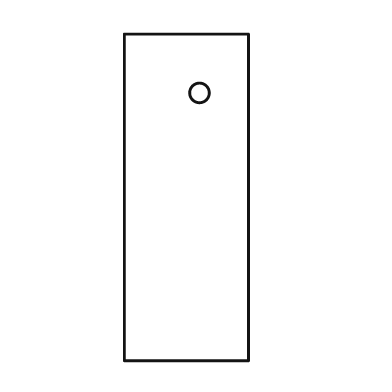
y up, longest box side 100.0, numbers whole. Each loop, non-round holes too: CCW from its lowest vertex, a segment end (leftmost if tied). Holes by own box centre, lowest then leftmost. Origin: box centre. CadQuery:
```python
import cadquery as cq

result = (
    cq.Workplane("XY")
    .moveTo(-19.0, -50.0)
    .lineTo(19.0, -50.0)
    .lineTo(19.0, 50.0)
    .lineTo(-19.0, 50.0)
    .close()
    .moveTo(4.0, 32.0)
    .circle(3.0)
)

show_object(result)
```